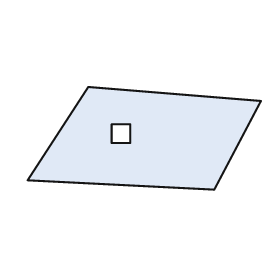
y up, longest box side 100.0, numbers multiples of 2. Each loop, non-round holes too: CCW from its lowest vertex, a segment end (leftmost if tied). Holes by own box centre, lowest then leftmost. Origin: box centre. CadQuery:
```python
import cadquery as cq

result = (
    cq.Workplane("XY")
    .moveTo(30.0, -22.0)
    .lineTo(50.0, 16.0)
    .lineTo(-24.0, 22.0)
    .lineTo(-50.0, -18.0)
    .close()
    .moveTo(-14.0, -2.0)
    .lineTo(-6.0, -2.0)
    .lineTo(-6.0, 6.0)
    .lineTo(-14.0, 6.0)
    .close()
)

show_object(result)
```